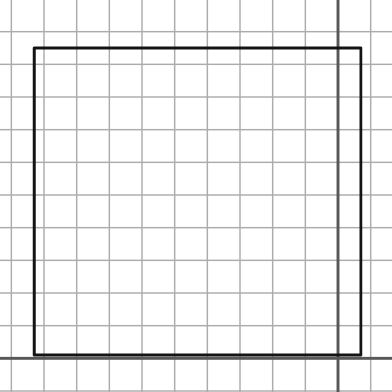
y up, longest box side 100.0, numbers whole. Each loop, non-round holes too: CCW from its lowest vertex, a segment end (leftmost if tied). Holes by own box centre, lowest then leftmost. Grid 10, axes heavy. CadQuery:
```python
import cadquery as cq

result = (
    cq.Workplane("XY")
    .moveTo(-93.0, 1.0)
    .lineTo(7.0, 1.0)
    .lineTo(7.0, 95.0)
    .lineTo(-93.0, 95.0)
    .close()
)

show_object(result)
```